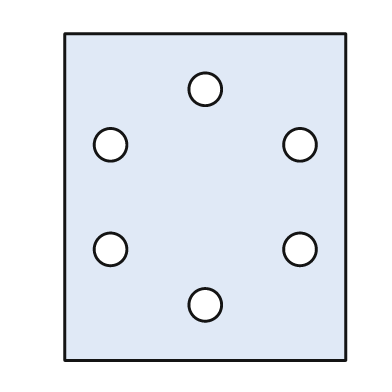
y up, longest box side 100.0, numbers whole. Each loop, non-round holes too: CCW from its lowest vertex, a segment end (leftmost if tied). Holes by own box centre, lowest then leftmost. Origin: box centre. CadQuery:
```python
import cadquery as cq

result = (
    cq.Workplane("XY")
    .moveTo(-43.0, -50.0)
    .lineTo(43.0, -50.0)
    .lineTo(43.0, 50.0)
    .lineTo(-43.0, 50.0)
    .close()
    .moveTo(0.0, -33.0)
    .circle(5.0)
    .moveTo(-29.0, -16.0)
    .circle(5.0)
    .moveTo(29.0, -16.0)
    .circle(5.0)
    .moveTo(-29.0, 16.0)
    .circle(5.0)
    .moveTo(29.0, 16.0)
    .circle(5.0)
    .moveTo(0.0, 33.0)
    .circle(5.0)
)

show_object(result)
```